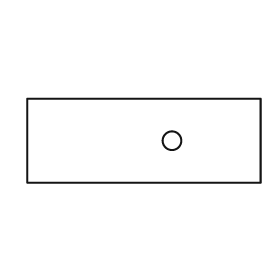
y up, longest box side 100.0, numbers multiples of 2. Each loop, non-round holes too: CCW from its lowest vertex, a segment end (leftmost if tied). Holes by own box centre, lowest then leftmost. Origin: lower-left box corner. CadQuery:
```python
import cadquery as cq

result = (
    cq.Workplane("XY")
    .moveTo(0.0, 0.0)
    .lineTo(100.0, 0.0)
    .lineTo(100.0, 36.0)
    .lineTo(0.0, 36.0)
    .close()
    .moveTo(62.0, 18.0)
    .circle(4.0)
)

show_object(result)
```